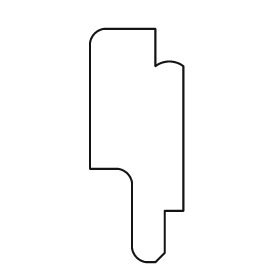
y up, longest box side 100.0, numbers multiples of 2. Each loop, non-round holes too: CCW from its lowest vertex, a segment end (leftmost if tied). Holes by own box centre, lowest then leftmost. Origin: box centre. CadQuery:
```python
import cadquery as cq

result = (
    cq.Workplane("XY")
    .moveTo(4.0, -50.0)
    .lineTo(8.0, -50.0)
    .lineTo(12.0, -46.0)
    .lineTo(12.0, -28.0)
    .lineTo(20.0, -28.0)
    .lineTo(20.0, 34.0)
    .threePointArc((14.0, 36.0), (8.0, 34.0))
    .lineTo(8.0, 50.0)
    .lineTo(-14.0, 50.0)
    .threePointArc((-18.0, 48.0), (-20.0, 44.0))
    .lineTo(-20.0, -10.0)
    .lineTo(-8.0, -10.0)
    .threePointArc((-4.0, -12.0), (-2.0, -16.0))
    .lineTo(-2.0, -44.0)
    .threePointArc((0.0, -48.0), (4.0, -50.0))
    .close()
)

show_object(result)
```